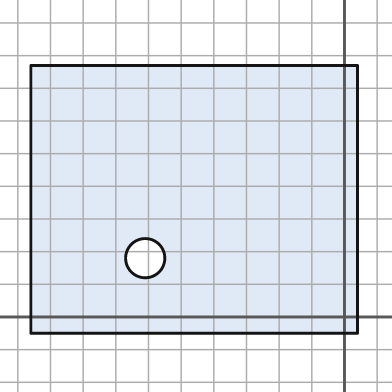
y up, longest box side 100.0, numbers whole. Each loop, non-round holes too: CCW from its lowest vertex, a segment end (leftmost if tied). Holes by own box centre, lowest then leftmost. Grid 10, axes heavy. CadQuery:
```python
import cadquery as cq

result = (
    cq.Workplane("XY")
    .moveTo(-96.0, -5.0)
    .lineTo(4.0, -5.0)
    .lineTo(4.0, 77.0)
    .lineTo(-96.0, 77.0)
    .close()
    .moveTo(-61.0, 18.0)
    .circle(6.0)
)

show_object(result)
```